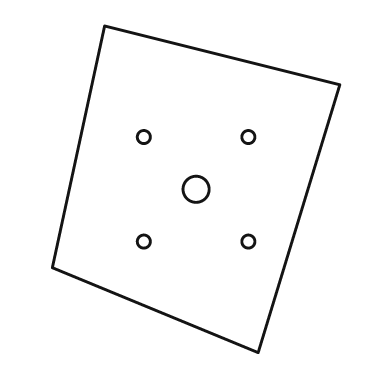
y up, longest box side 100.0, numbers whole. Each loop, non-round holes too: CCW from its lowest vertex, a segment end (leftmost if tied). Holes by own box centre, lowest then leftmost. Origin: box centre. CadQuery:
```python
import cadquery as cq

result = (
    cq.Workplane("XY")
    .moveTo(19.0, -50.0)
    .lineTo(44.0, 32.0)
    .lineTo(-28.0, 50.0)
    .lineTo(-44.0, -24.0)
    .close()
    .moveTo(-16.0, -16.0)
    .circle(2.0)
    .moveTo(16.0, -16.0)
    .circle(2.0)
    .moveTo(0.0, 0.0)
    .circle(4.0)
    .moveTo(-16.0, 16.0)
    .circle(2.0)
    .moveTo(16.0, 16.0)
    .circle(2.0)
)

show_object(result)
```